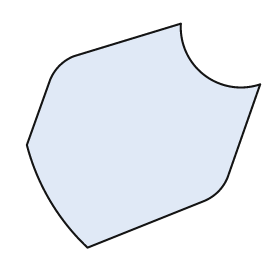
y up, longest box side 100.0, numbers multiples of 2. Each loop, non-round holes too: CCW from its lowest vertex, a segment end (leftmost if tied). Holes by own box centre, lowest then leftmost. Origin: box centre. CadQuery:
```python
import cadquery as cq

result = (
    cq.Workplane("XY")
    .moveTo(-24.0, -48.0)
    .lineTo(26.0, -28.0)
    .threePointArc((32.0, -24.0), (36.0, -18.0))
    .lineTo(50.0, 22.0)
    .threePointArc((26.0, 26.0), (16.0, 48.0))
    .lineTo(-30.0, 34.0)
    .threePointArc((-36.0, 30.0), (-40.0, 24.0))
    .lineTo(-50.0, -4.0)
    .threePointArc((-40.0, -28.0), (-24.0, -48.0))
    .close()
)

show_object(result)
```